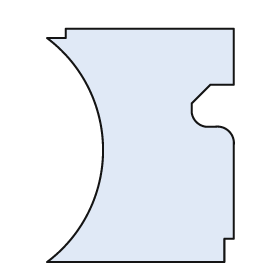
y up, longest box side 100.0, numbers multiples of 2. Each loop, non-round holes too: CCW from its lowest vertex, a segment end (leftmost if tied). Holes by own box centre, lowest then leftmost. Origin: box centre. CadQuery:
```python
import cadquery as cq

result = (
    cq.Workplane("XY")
    .moveTo(-40.0, -50.0)
    .lineTo(36.0, -50.0)
    .lineTo(36.0, -40.0)
    .lineTo(40.0, -40.0)
    .lineTo(40.0, 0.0)
    .threePointArc((38.0, 6.0), (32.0, 8.0))
    .lineTo(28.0, 8.0)
    .threePointArc((24.0, 10.0), (22.0, 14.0))
    .lineTo(22.0, 18.0)
    .lineTo(30.0, 26.0)
    .lineTo(40.0, 26.0)
    .lineTo(40.0, 50.0)
    .lineTo(-32.0, 50.0)
    .lineTo(-32.0, 46.0)
    .lineTo(-40.0, 46.0)
    .threePointArc((-16.0, -2.0), (-40.0, -50.0))
    .close()
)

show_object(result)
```